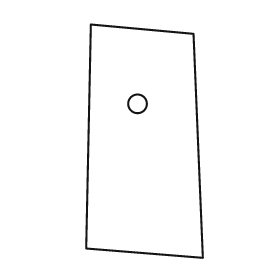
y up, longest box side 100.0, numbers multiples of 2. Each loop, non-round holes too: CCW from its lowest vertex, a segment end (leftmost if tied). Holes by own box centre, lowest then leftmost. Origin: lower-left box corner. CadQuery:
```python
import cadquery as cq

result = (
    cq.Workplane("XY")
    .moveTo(50.0, 0.0)
    .lineTo(46.0, 96.0)
    .lineTo(2.0, 100.0)
    .lineTo(0.0, 4.0)
    .close()
    .moveTo(22.0, 66.0)
    .circle(4.0)
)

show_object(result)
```